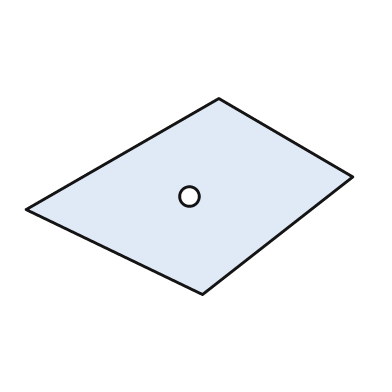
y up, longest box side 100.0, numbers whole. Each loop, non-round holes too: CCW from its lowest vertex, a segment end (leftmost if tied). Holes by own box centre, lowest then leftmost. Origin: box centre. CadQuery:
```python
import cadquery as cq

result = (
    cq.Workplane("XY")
    .moveTo(4.0, -30.0)
    .lineTo(50.0, 6.0)
    .lineTo(9.0, 30.0)
    .lineTo(-50.0, -4.0)
    .close()
    .moveTo(0.0, 0.0)
    .circle(3.0)
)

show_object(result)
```